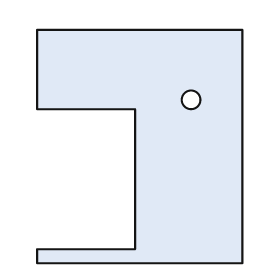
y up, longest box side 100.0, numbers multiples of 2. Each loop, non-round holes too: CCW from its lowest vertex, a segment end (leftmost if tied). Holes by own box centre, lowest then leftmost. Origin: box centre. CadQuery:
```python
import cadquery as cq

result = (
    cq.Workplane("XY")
    .moveTo(-44.0, -50.0)
    .lineTo(44.0, -50.0)
    .lineTo(44.0, 50.0)
    .lineTo(-44.0, 50.0)
    .lineTo(-44.0, 16.0)
    .lineTo(-2.0, 16.0)
    .lineTo(-2.0, -44.0)
    .lineTo(-44.0, -44.0)
    .close()
    .moveTo(22.0, 20.0)
    .circle(4.0)
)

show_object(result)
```